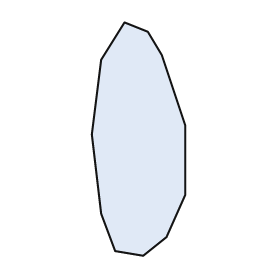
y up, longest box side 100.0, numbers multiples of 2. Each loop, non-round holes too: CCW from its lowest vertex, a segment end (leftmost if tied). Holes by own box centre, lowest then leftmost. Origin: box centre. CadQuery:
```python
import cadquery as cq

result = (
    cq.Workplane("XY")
    .moveTo(2.0, -50.0)
    .lineTo(12.0, -42.0)
    .lineTo(20.0, -24.0)
    .lineTo(20.0, 6.0)
    .lineTo(10.0, 36.0)
    .lineTo(4.0, 46.0)
    .lineTo(-6.0, 50.0)
    .lineTo(-16.0, 34.0)
    .lineTo(-20.0, 2.0)
    .lineTo(-16.0, -32.0)
    .lineTo(-10.0, -48.0)
    .close()
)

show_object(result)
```